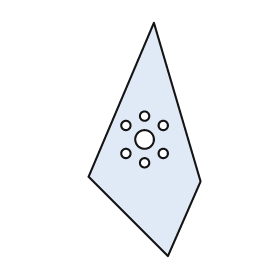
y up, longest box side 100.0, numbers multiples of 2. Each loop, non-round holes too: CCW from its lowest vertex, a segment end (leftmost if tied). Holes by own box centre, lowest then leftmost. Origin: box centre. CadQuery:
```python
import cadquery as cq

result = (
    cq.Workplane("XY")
    .moveTo(10.0, -50.0)
    .lineTo(24.0, -18.0)
    .lineTo(4.0, 50.0)
    .lineTo(-24.0, -16.0)
    .close()
    .moveTo(0.0, -10.0)
    .circle(2.0)
    .moveTo(-8.0, -6.0)
    .circle(2.0)
    .moveTo(8.0, -6.0)
    .circle(2.0)
    .moveTo(0.0, 0.0)
    .circle(4.0)
    .moveTo(-8.0, 6.0)
    .circle(2.0)
    .moveTo(8.0, 6.0)
    .circle(2.0)
    .moveTo(0.0, 10.0)
    .circle(2.0)
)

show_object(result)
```